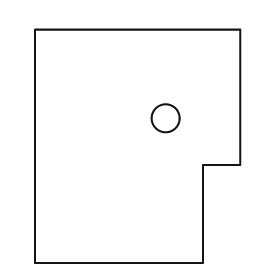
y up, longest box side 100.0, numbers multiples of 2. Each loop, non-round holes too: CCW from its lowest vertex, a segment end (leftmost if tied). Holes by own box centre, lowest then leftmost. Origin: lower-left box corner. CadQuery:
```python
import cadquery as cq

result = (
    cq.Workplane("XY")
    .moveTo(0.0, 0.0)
    .lineTo(72.0, 0.0)
    .lineTo(72.0, 42.0)
    .lineTo(88.0, 42.0)
    .lineTo(88.0, 100.0)
    .lineTo(0.0, 100.0)
    .close()
    .moveTo(56.0, 62.0)
    .circle(6.0)
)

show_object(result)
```